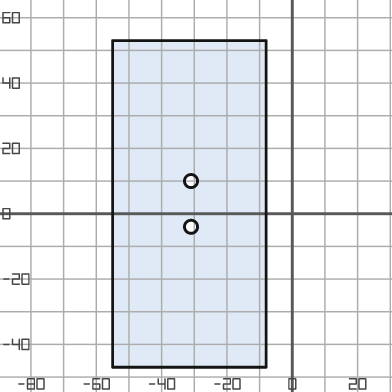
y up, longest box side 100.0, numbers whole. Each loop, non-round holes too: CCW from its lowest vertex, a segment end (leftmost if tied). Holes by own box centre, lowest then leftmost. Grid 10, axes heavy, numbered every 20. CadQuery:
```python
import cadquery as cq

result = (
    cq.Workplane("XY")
    .moveTo(-55.0, -47.0)
    .lineTo(-8.0, -47.0)
    .lineTo(-8.0, 53.0)
    .lineTo(-55.0, 53.0)
    .close()
    .moveTo(-31.0, -4.0)
    .circle(2.0)
    .moveTo(-31.0, 10.0)
    .circle(2.0)
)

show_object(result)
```